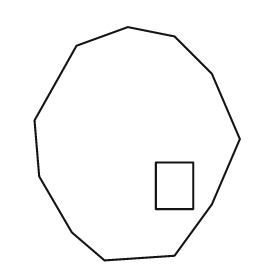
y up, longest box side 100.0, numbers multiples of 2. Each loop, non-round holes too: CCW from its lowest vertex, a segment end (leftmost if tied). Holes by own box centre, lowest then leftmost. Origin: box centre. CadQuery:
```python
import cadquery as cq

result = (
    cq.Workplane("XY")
    .moveTo(-14.0, -50.0)
    .lineTo(16.0, -48.0)
    .lineTo(32.0, -26.0)
    .lineTo(44.0, 2.0)
    .lineTo(32.0, 30.0)
    .lineTo(16.0, 46.0)
    .lineTo(-4.0, 50.0)
    .lineTo(-26.0, 42.0)
    .lineTo(-44.0, 10.0)
    .lineTo(-42.0, -14.0)
    .lineTo(-28.0, -38.0)
    .close()
    .moveTo(8.0, -28.0)
    .lineTo(24.0, -28.0)
    .lineTo(24.0, -8.0)
    .lineTo(8.0, -8.0)
    .close()
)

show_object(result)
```